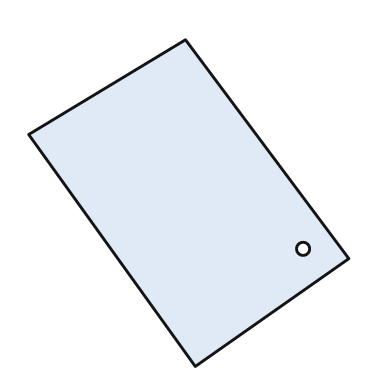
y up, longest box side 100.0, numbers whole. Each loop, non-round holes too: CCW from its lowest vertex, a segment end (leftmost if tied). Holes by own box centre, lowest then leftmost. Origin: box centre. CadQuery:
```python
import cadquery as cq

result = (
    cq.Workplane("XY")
    .moveTo(2.0, -50.0)
    .lineTo(49.0, -17.0)
    .lineTo(-1.0, 50.0)
    .lineTo(-49.0, 21.0)
    .close()
    .moveTo(35.0, -14.0)
    .circle(2.0)
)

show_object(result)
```